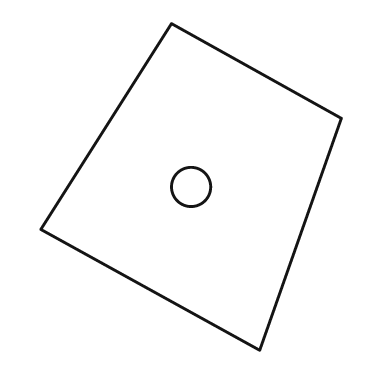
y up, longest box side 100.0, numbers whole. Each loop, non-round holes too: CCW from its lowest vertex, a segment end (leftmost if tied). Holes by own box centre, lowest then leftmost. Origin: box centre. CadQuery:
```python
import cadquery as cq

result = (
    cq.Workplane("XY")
    .moveTo(21.0, -50.0)
    .lineTo(46.0, 21.0)
    .lineTo(-6.0, 50.0)
    .lineTo(-46.0, -13.0)
    .close()
    .moveTo(0.0, 0.0)
    .circle(6.0)
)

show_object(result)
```